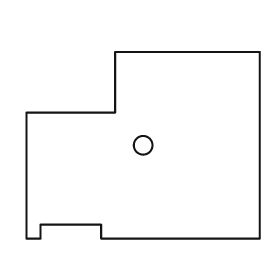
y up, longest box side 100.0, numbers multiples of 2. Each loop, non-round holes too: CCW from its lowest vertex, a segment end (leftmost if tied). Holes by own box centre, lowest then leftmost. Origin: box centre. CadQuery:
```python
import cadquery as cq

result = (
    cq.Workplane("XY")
    .moveTo(-50.0, -40.0)
    .lineTo(-44.0, -40.0)
    .lineTo(-44.0, -34.0)
    .lineTo(-18.0, -34.0)
    .lineTo(-18.0, -40.0)
    .lineTo(50.0, -40.0)
    .lineTo(50.0, 40.0)
    .lineTo(-12.0, 40.0)
    .lineTo(-12.0, 14.0)
    .lineTo(-50.0, 14.0)
    .close()
    .moveTo(0.0, 0.0)
    .circle(4.0)
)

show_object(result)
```